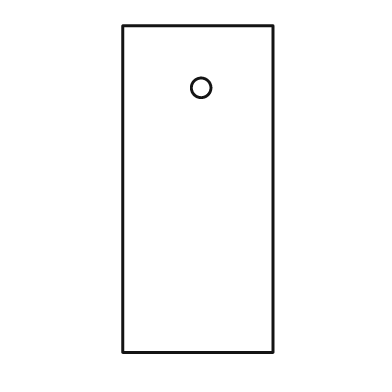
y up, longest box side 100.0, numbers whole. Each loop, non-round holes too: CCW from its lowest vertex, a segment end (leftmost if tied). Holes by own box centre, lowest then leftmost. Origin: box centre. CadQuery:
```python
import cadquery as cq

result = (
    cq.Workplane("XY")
    .moveTo(-23.0, -50.0)
    .lineTo(23.0, -50.0)
    .lineTo(23.0, 50.0)
    .lineTo(-23.0, 50.0)
    .close()
    .moveTo(1.0, 31.0)
    .circle(3.0)
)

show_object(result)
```